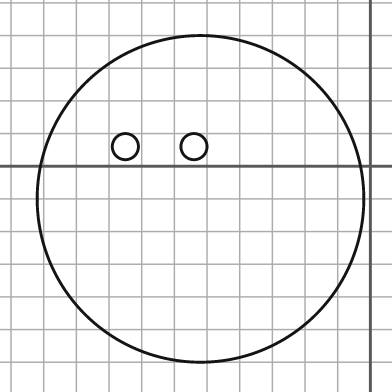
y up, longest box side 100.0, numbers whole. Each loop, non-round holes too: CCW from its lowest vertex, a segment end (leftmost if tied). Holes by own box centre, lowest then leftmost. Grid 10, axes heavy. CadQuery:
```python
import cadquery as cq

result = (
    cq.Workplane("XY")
    .moveTo(-52.0, -10.0)
    .circle(50.0)
    .moveTo(-75.0, 6.0)
    .circle(4.0)
    .moveTo(-54.0, 6.0)
    .circle(4.0)
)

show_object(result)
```